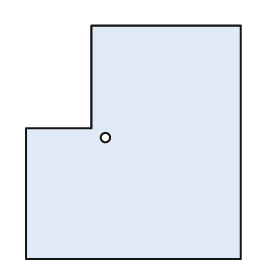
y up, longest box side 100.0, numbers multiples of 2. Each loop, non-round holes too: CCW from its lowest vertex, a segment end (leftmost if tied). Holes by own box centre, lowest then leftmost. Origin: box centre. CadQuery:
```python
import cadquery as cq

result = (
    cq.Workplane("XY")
    .moveTo(-46.0, -50.0)
    .lineTo(46.0, -50.0)
    .lineTo(46.0, 50.0)
    .lineTo(-18.0, 50.0)
    .lineTo(-18.0, 6.0)
    .lineTo(-46.0, 6.0)
    .close()
    .moveTo(-12.0, 2.0)
    .circle(2.0)
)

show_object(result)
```